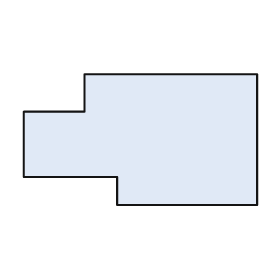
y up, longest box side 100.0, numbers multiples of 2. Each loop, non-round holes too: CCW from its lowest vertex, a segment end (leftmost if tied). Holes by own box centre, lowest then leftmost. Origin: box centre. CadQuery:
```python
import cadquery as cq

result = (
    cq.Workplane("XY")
    .moveTo(-10.0, -28.0)
    .lineTo(50.0, -28.0)
    .lineTo(50.0, 28.0)
    .lineTo(-24.0, 28.0)
    .lineTo(-24.0, 12.0)
    .lineTo(-50.0, 12.0)
    .lineTo(-50.0, -16.0)
    .lineTo(-10.0, -16.0)
    .close()
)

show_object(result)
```